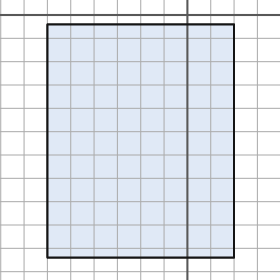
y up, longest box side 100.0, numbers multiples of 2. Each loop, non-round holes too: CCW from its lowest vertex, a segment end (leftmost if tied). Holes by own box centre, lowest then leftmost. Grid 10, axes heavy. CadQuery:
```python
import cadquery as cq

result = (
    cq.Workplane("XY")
    .moveTo(-60.0, -104.0)
    .lineTo(20.0, -104.0)
    .lineTo(20.0, -4.0)
    .lineTo(-60.0, -4.0)
    .close()
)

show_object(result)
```